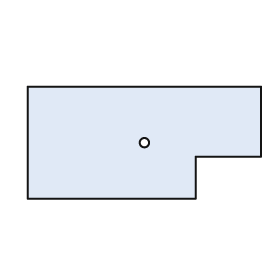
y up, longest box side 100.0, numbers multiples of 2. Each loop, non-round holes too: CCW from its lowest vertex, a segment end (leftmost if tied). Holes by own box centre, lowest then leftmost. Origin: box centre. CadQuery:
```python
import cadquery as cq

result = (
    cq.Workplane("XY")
    .moveTo(-50.0, -24.0)
    .lineTo(22.0, -24.0)
    .lineTo(22.0, -6.0)
    .lineTo(50.0, -6.0)
    .lineTo(50.0, 24.0)
    .lineTo(-50.0, 24.0)
    .close()
    .moveTo(0.0, 0.0)
    .circle(2.0)
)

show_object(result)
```